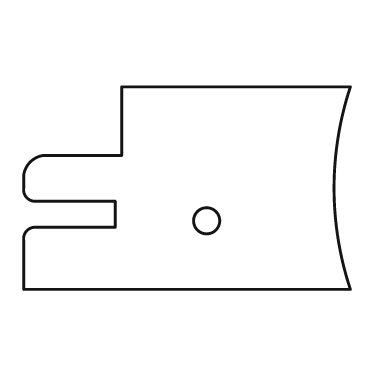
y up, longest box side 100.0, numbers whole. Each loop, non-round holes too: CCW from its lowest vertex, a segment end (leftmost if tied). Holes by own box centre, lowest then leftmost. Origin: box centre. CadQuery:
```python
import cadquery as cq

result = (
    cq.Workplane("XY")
    .moveTo(-50.0, -31.0)
    .lineTo(50.0, -31.0)
    .threePointArc((45.0, 0.0), (50.0, 31.0))
    .lineTo(-20.0, 31.0)
    .lineTo(-20.0, 10.0)
    .lineTo(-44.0, 10.0)
    .threePointArc((-48.0, 8.0), (-50.0, 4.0))
    .lineTo(-50.0, 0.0)
    .threePointArc((-49.0, -3.0), (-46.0, -4.0))
    .lineTo(-22.0, -4.0)
    .lineTo(-22.0, -12.0)
    .lineTo(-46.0, -12.0)
    .threePointArc((-49.0, -13.0), (-50.0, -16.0))
    .close()
    .moveTo(6.0, -10.0)
    .circle(4.0)
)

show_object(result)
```